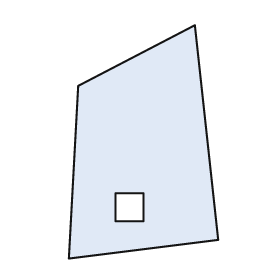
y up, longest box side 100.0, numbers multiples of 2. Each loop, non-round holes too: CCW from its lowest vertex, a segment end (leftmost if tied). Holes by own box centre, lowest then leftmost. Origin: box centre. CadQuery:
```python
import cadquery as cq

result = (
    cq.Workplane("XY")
    .moveTo(-32.0, -50.0)
    .lineTo(32.0, -42.0)
    .lineTo(22.0, 50.0)
    .lineTo(-28.0, 24.0)
    .close()
    .moveTo(-12.0, -34.0)
    .lineTo(0.0, -34.0)
    .lineTo(0.0, -22.0)
    .lineTo(-12.0, -22.0)
    .close()
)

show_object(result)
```